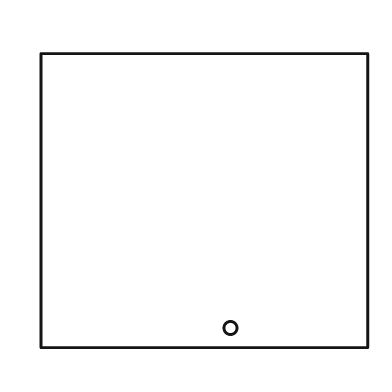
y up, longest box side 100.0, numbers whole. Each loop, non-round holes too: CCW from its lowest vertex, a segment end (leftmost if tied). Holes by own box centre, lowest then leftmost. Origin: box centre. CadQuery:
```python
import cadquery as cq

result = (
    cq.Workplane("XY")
    .moveTo(-50.0, -45.0)
    .lineTo(50.0, -45.0)
    .lineTo(50.0, 45.0)
    .lineTo(-50.0, 45.0)
    .close()
    .moveTo(8.0, -39.0)
    .circle(2.0)
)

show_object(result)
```